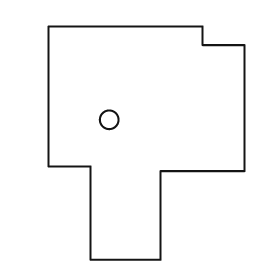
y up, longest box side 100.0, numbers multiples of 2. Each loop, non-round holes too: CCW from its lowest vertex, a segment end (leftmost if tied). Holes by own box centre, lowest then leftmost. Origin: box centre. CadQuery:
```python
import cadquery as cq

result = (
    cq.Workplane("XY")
    .moveTo(-24.0, -50.0)
    .lineTo(6.0, -50.0)
    .lineTo(6.0, -12.0)
    .lineTo(42.0, -12.0)
    .lineTo(42.0, 42.0)
    .lineTo(24.0, 42.0)
    .lineTo(24.0, 50.0)
    .lineTo(-42.0, 50.0)
    .lineTo(-42.0, -10.0)
    .lineTo(-24.0, -10.0)
    .close()
    .moveTo(-16.0, 10.0)
    .circle(4.0)
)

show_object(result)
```